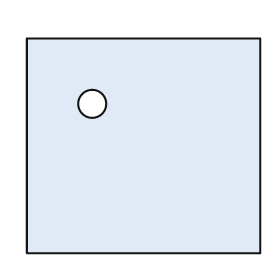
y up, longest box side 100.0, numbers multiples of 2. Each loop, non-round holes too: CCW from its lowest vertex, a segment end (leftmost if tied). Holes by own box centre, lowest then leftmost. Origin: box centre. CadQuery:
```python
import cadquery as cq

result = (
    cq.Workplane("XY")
    .moveTo(-50.0, -46.0)
    .lineTo(50.0, -46.0)
    .lineTo(50.0, 46.0)
    .lineTo(-50.0, 46.0)
    .close()
    .moveTo(-22.0, 18.0)
    .circle(6.0)
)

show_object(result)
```